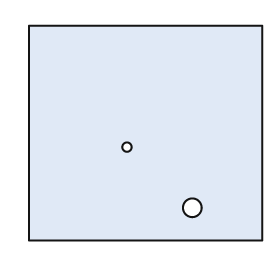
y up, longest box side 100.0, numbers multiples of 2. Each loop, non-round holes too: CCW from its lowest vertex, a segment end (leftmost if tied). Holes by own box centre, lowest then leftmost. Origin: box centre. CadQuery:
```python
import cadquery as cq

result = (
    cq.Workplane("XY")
    .moveTo(-50.0, -46.0)
    .lineTo(50.0, -46.0)
    .lineTo(50.0, 46.0)
    .lineTo(-50.0, 46.0)
    .close()
    .moveTo(20.0, -32.0)
    .circle(4.0)
    .moveTo(-8.0, -6.0)
    .circle(2.0)
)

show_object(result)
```